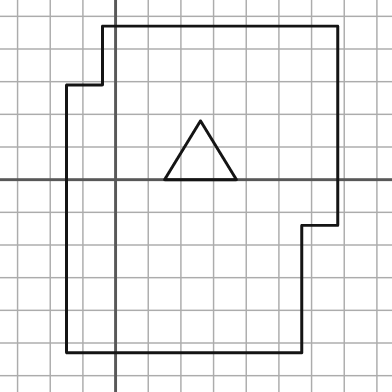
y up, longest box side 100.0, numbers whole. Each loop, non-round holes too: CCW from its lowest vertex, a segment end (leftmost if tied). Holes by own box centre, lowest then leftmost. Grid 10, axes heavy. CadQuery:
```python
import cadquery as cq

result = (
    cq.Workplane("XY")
    .moveTo(-15.0, -53.0)
    .lineTo(57.0, -53.0)
    .lineTo(57.0, -14.0)
    .lineTo(68.0, -14.0)
    .lineTo(68.0, 47.0)
    .lineTo(-4.0, 47.0)
    .lineTo(-4.0, 29.0)
    .lineTo(-15.0, 29.0)
    .close()
    .moveTo(15.0, 0.0)
    .lineTo(37.0, 0.0)
    .lineTo(26.0, 18.0)
    .close()
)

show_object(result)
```